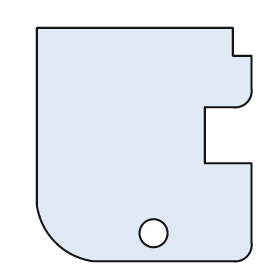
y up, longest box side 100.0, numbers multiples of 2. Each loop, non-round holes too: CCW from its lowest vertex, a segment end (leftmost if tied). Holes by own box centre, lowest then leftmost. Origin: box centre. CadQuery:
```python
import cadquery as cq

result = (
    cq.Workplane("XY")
    .moveTo(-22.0, -50.0)
    .lineTo(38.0, -50.0)
    .threePointArc((44.0, -48.0), (46.0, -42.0))
    .lineTo(46.0, -8.0)
    .lineTo(26.0, -8.0)
    .lineTo(26.0, 16.0)
    .lineTo(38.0, 16.0)
    .threePointArc((44.0, 18.0), (46.0, 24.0))
    .lineTo(46.0, 38.0)
    .lineTo(38.0, 38.0)
    .lineTo(38.0, 50.0)
    .lineTo(-46.0, 50.0)
    .lineTo(-46.0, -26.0)
    .threePointArc((-38.0, -42.0), (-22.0, -50.0))
    .close()
    .moveTo(4.0, -38.0)
    .circle(6.0)
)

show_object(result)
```